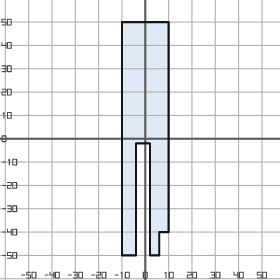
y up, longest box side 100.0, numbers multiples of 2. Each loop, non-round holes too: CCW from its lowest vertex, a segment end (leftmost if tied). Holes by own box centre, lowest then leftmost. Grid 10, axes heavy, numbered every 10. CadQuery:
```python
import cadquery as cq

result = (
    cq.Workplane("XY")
    .moveTo(-10.0, -50.0)
    .lineTo(-4.0, -50.0)
    .lineTo(-4.0, -2.0)
    .lineTo(2.0, -2.0)
    .lineTo(2.0, -50.0)
    .lineTo(6.0, -50.0)
    .lineTo(6.0, -40.0)
    .lineTo(10.0, -40.0)
    .lineTo(10.0, 50.0)
    .lineTo(-10.0, 50.0)
    .close()
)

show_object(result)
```